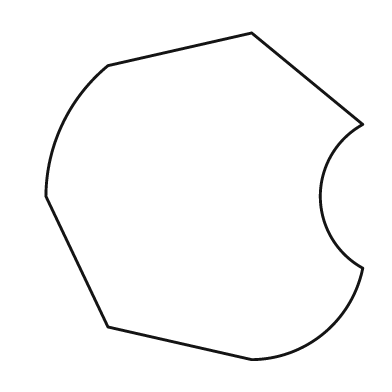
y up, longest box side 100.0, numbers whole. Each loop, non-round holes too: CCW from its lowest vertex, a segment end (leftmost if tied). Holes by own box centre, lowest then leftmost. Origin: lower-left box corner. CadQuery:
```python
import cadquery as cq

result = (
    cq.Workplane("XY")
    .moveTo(63.0, 0.0)
    .threePointArc((85.0, 8.0), (97.0, 28.0))
    .threePointArc((84.0, 50.0), (97.0, 72.0))
    .lineTo(63.0, 100.0)
    .lineTo(19.0, 90.0)
    .threePointArc((5.0, 72.0), (0.0, 50.0))
    .lineTo(19.0, 10.0)
    .close()
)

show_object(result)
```